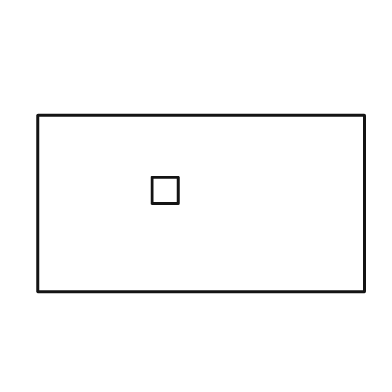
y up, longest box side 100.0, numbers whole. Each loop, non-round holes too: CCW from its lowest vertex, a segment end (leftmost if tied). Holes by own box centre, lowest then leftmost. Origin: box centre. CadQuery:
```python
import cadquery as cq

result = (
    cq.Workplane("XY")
    .moveTo(-50.0, -27.0)
    .lineTo(50.0, -27.0)
    .lineTo(50.0, 27.0)
    .lineTo(-50.0, 27.0)
    .close()
    .moveTo(-15.0, 0.0)
    .lineTo(-7.0, 0.0)
    .lineTo(-7.0, 8.0)
    .lineTo(-15.0, 8.0)
    .close()
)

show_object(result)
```